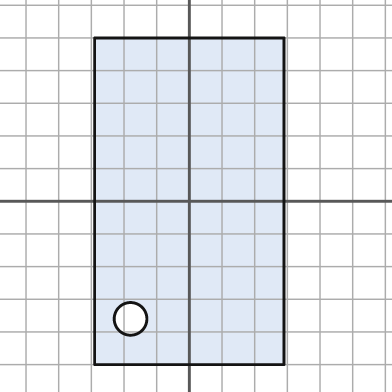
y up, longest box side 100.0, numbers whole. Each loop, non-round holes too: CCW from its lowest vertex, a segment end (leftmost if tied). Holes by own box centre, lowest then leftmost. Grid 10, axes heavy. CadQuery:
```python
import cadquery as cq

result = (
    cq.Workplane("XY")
    .moveTo(-29.0, -50.0)
    .lineTo(29.0, -50.0)
    .lineTo(29.0, 50.0)
    .lineTo(-29.0, 50.0)
    .close()
    .moveTo(-18.0, -36.0)
    .circle(5.0)
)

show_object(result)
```